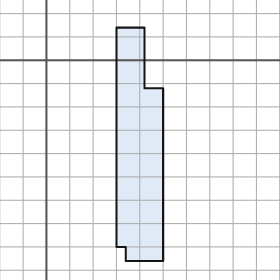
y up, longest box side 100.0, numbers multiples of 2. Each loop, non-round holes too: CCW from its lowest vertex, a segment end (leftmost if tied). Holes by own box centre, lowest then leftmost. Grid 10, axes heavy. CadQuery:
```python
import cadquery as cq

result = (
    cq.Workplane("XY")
    .moveTo(34.0, -86.0)
    .lineTo(50.0, -86.0)
    .lineTo(50.0, -12.0)
    .lineTo(42.0, -12.0)
    .lineTo(42.0, 14.0)
    .lineTo(30.0, 14.0)
    .lineTo(30.0, -80.0)
    .lineTo(34.0, -80.0)
    .close()
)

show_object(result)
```